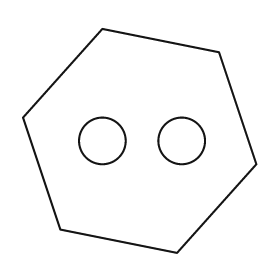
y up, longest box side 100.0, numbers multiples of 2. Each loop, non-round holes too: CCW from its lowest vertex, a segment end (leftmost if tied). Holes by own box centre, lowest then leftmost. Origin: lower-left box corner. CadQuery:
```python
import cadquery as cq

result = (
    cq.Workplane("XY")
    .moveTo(66.0, 0.0)
    .lineTo(100.0, 38.0)
    .lineTo(84.0, 86.0)
    .lineTo(34.0, 96.0)
    .lineTo(0.0, 58.0)
    .lineTo(16.0, 10.0)
    .close()
    .moveTo(34.0, 48.0)
    .circle(10.0)
    .moveTo(68.0, 48.0)
    .circle(10.0)
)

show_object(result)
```